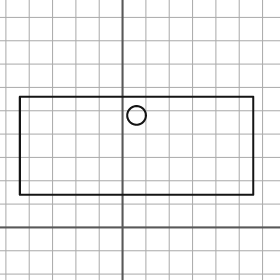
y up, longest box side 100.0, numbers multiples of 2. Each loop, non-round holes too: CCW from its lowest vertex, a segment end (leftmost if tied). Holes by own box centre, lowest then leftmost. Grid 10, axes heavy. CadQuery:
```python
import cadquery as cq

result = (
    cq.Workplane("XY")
    .moveTo(-44.0, 14.0)
    .lineTo(56.0, 14.0)
    .lineTo(56.0, 56.0)
    .lineTo(-44.0, 56.0)
    .close()
    .moveTo(6.0, 48.0)
    .circle(4.0)
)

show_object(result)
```